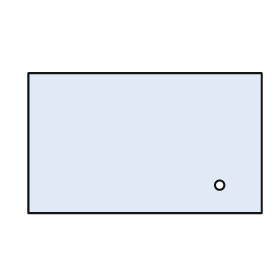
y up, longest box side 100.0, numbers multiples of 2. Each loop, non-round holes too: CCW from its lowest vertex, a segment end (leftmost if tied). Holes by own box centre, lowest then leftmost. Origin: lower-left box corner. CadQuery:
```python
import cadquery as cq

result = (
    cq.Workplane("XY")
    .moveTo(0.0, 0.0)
    .lineTo(100.0, 0.0)
    .lineTo(100.0, 60.0)
    .lineTo(0.0, 60.0)
    .close()
    .moveTo(82.0, 12.0)
    .circle(2.0)
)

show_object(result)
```